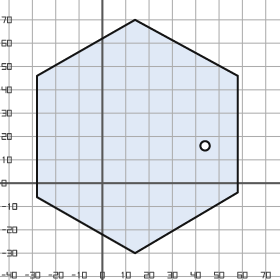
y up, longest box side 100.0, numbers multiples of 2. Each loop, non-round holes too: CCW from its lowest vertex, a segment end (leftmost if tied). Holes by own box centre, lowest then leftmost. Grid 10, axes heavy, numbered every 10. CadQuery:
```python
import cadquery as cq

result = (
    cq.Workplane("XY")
    .moveTo(14.0, -30.0)
    .lineTo(58.0, -4.0)
    .lineTo(58.0, 46.0)
    .lineTo(14.0, 70.0)
    .lineTo(-28.0, 46.0)
    .lineTo(-28.0, -6.0)
    .close()
    .moveTo(44.0, 16.0)
    .circle(2.0)
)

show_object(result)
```